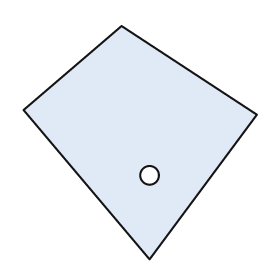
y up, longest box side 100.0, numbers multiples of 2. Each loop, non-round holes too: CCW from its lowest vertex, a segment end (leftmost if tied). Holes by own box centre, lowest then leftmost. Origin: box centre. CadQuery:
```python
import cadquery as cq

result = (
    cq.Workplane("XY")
    .moveTo(4.0, -50.0)
    .lineTo(50.0, 12.0)
    .lineTo(-8.0, 50.0)
    .lineTo(-50.0, 14.0)
    .close()
    .moveTo(4.0, -14.0)
    .circle(4.0)
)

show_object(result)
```